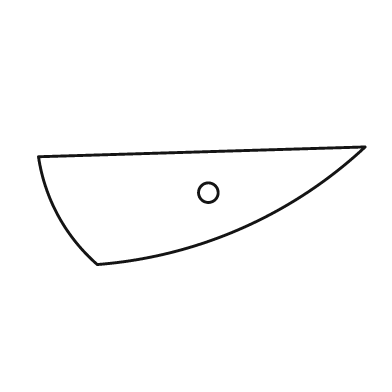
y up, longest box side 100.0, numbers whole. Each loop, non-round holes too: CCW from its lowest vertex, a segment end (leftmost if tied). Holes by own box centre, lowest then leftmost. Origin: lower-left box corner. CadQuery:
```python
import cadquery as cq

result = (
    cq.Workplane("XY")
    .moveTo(18.0, 0.0)
    .threePointArc((62.0, 11.0), (100.0, 36.0))
    .lineTo(0.0, 33.0)
    .threePointArc((6.0, 15.0), (18.0, 0.0))
    .close()
    .moveTo(52.0, 22.0)
    .circle(3.0)
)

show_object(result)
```